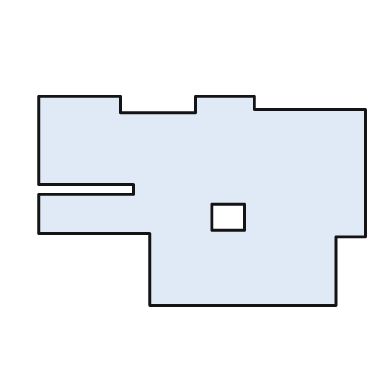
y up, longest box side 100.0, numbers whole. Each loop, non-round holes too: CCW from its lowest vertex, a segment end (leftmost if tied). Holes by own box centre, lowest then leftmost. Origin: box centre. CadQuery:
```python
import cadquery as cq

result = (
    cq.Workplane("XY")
    .moveTo(-16.0, -32.0)
    .lineTo(41.0, -32.0)
    .lineTo(41.0, -11.0)
    .lineTo(50.0, -11.0)
    .lineTo(50.0, 28.0)
    .lineTo(16.0, 28.0)
    .lineTo(16.0, 32.0)
    .lineTo(-2.0, 32.0)
    .lineTo(-2.0, 27.0)
    .lineTo(-25.0, 27.0)
    .lineTo(-25.0, 32.0)
    .lineTo(-50.0, 32.0)
    .lineTo(-50.0, 5.0)
    .lineTo(-21.0, 5.0)
    .lineTo(-21.0, 2.0)
    .lineTo(-50.0, 2.0)
    .lineTo(-50.0, -10.0)
    .lineTo(-16.0, -10.0)
    .close()
    .moveTo(3.0, -9.0)
    .lineTo(13.0, -9.0)
    .lineTo(13.0, -1.0)
    .lineTo(3.0, -1.0)
    .close()
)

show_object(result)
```